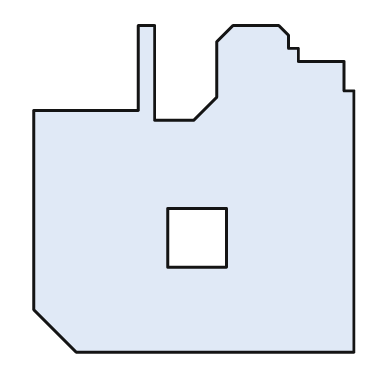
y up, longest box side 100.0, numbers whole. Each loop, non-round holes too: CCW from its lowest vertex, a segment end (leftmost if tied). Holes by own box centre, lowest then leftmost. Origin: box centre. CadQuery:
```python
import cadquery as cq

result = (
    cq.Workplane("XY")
    .moveTo(-36.0, -50.0)
    .lineTo(49.0, -50.0)
    .lineTo(49.0, 30.0)
    .lineTo(46.0, 30.0)
    .lineTo(46.0, 39.0)
    .lineTo(32.0, 39.0)
    .lineTo(32.0, 43.0)
    .lineTo(29.0, 43.0)
    .lineTo(29.0, 47.0)
    .lineTo(26.0, 50.0)
    .lineTo(12.0, 50.0)
    .lineTo(7.0, 45.0)
    .lineTo(7.0, 28.0)
    .lineTo(0.0, 21.0)
    .lineTo(-12.0, 21.0)
    .lineTo(-12.0, 50.0)
    .lineTo(-17.0, 50.0)
    .lineTo(-17.0, 24.0)
    .lineTo(-49.0, 24.0)
    .lineTo(-49.0, -37.0)
    .close()
    .moveTo(-8.0, -24.0)
    .lineTo(10.0, -24.0)
    .lineTo(10.0, -6.0)
    .lineTo(-8.0, -6.0)
    .close()
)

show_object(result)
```